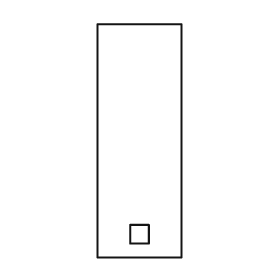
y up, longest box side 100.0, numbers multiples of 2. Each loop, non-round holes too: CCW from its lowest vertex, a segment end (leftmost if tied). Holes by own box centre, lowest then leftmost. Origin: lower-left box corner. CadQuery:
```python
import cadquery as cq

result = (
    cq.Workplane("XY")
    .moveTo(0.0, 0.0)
    .lineTo(36.0, 0.0)
    .lineTo(36.0, 100.0)
    .lineTo(0.0, 100.0)
    .close()
    .moveTo(14.0, 6.0)
    .lineTo(22.0, 6.0)
    .lineTo(22.0, 14.0)
    .lineTo(14.0, 14.0)
    .close()
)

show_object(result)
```